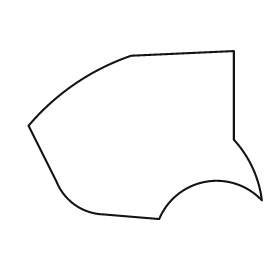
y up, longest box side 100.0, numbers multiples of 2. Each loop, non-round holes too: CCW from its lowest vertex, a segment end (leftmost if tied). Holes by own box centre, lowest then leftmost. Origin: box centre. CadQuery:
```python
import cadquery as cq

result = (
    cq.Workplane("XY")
    .moveTo(6.0, -36.0)
    .threePointArc((26.0, -20.0), (50.0, -28.0))
    .threePointArc((46.0, -14.0), (38.0, -2.0))
    .lineTo(38.0, 36.0)
    .lineTo(-6.0, 34.0)
    .threePointArc((-30.0, 22.0), (-50.0, 4.0))
    .lineTo(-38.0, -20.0)
    .threePointArc((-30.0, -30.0), (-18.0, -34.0))
    .close()
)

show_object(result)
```